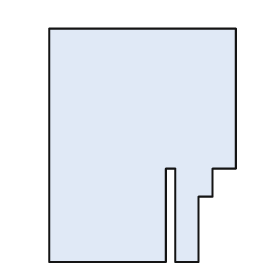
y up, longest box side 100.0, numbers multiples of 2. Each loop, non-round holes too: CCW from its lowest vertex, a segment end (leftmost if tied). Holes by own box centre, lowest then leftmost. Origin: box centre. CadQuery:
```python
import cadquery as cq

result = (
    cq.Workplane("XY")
    .moveTo(-40.0, -50.0)
    .lineTo(10.0, -50.0)
    .lineTo(10.0, -10.0)
    .lineTo(14.0, -10.0)
    .lineTo(14.0, -50.0)
    .lineTo(24.0, -50.0)
    .lineTo(24.0, -22.0)
    .lineTo(30.0, -22.0)
    .lineTo(30.0, -10.0)
    .lineTo(40.0, -10.0)
    .lineTo(40.0, 50.0)
    .lineTo(-40.0, 50.0)
    .close()
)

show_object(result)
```